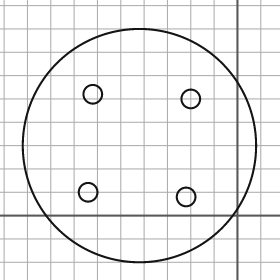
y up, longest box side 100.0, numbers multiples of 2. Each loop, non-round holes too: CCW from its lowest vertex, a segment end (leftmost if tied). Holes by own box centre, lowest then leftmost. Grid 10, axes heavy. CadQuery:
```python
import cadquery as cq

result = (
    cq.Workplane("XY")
    .moveTo(-42.0, 30.0)
    .circle(50.0)
    .moveTo(-22.0, 8.0)
    .circle(4.0)
    .moveTo(-64.0, 10.0)
    .circle(4.0)
    .moveTo(-20.0, 50.0)
    .circle(4.0)
    .moveTo(-62.0, 52.0)
    .circle(4.0)
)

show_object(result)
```